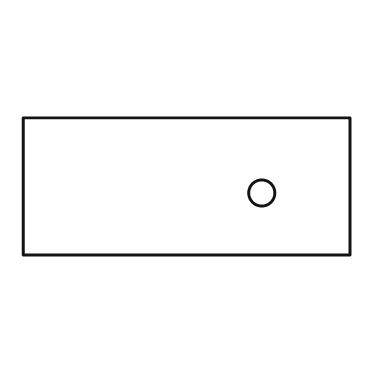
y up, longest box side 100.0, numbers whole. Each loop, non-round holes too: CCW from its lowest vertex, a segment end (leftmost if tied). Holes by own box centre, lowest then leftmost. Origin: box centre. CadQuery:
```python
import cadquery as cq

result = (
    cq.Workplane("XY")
    .moveTo(-50.0, -21.0)
    .lineTo(50.0, -21.0)
    .lineTo(50.0, 21.0)
    .lineTo(-50.0, 21.0)
    .close()
    .moveTo(23.0, -2.0)
    .circle(4.0)
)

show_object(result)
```